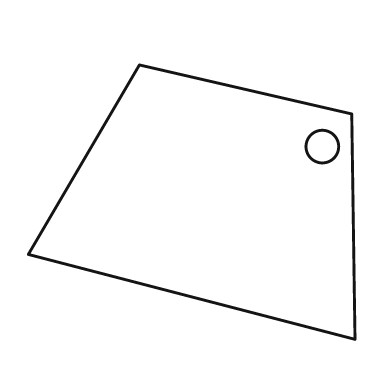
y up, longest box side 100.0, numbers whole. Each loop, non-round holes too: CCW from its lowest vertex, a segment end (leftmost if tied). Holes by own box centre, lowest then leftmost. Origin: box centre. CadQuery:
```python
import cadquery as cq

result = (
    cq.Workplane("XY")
    .moveTo(50.0, -42.0)
    .lineTo(49.0, 27.0)
    .lineTo(-16.0, 42.0)
    .lineTo(-50.0, -16.0)
    .close()
    .moveTo(40.0, 17.0)
    .circle(5.0)
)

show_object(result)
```